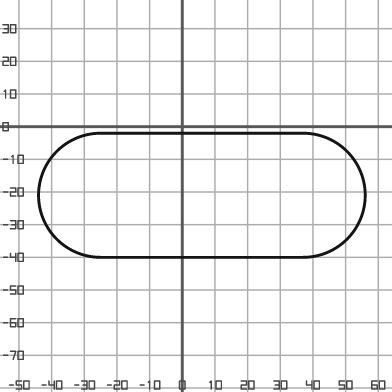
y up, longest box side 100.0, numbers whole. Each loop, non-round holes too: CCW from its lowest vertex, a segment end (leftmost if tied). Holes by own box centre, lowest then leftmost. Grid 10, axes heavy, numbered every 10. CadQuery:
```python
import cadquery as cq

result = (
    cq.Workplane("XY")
    .moveTo(-25.0, -40.0)
    .lineTo(37.0, -40.0)
    .threePointArc((56.0, -21.0), (37.0, -2.0))
    .lineTo(-25.0, -2.0)
    .threePointArc((-44.0, -21.0), (-25.0, -40.0))
    .close()
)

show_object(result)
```